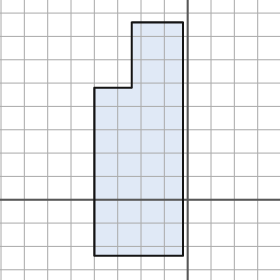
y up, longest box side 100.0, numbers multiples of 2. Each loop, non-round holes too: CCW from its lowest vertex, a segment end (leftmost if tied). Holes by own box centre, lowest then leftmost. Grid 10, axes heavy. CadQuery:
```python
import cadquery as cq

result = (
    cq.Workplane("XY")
    .moveTo(-40.0, -24.0)
    .lineTo(-2.0, -24.0)
    .lineTo(-2.0, 76.0)
    .lineTo(-24.0, 76.0)
    .lineTo(-24.0, 48.0)
    .lineTo(-40.0, 48.0)
    .close()
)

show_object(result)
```